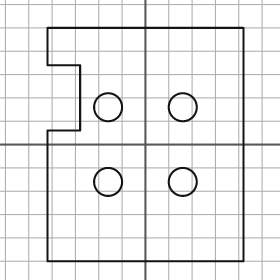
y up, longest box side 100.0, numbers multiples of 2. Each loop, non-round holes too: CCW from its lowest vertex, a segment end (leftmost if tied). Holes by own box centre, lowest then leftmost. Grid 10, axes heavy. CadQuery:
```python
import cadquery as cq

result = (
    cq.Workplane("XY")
    .moveTo(-42.0, -50.0)
    .lineTo(42.0, -50.0)
    .lineTo(42.0, 50.0)
    .lineTo(-42.0, 50.0)
    .lineTo(-42.0, 34.0)
    .lineTo(-28.0, 34.0)
    .lineTo(-28.0, 6.0)
    .lineTo(-42.0, 6.0)
    .close()
    .moveTo(-16.0, -16.0)
    .circle(6.0)
    .moveTo(16.0, -16.0)
    .circle(6.0)
    .moveTo(-16.0, 16.0)
    .circle(6.0)
    .moveTo(16.0, 16.0)
    .circle(6.0)
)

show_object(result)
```